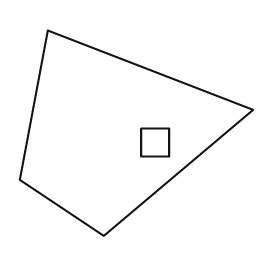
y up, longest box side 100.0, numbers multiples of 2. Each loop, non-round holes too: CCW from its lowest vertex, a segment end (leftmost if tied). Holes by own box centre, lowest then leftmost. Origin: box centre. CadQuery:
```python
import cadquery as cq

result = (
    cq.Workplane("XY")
    .moveTo(-14.0, -44.0)
    .lineTo(50.0, 10.0)
    .lineTo(-38.0, 44.0)
    .lineTo(-50.0, -20.0)
    .close()
    .moveTo(2.0, -10.0)
    .lineTo(14.0, -10.0)
    .lineTo(14.0, 2.0)
    .lineTo(2.0, 2.0)
    .close()
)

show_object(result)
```